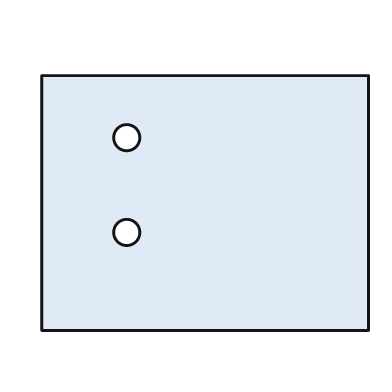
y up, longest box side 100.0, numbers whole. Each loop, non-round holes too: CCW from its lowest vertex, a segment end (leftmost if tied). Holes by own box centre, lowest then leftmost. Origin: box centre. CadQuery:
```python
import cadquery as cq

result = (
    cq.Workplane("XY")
    .moveTo(-50.0, -39.0)
    .lineTo(50.0, -39.0)
    .lineTo(50.0, 39.0)
    .lineTo(-50.0, 39.0)
    .close()
    .moveTo(-24.0, -9.0)
    .circle(4.0)
    .moveTo(-24.0, 20.0)
    .circle(4.0)
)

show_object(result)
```